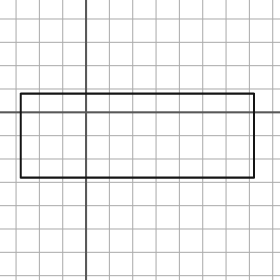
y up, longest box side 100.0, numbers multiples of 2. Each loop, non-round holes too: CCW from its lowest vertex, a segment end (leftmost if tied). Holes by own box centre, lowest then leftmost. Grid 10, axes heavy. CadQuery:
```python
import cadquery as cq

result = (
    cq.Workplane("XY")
    .moveTo(-28.0, -28.0)
    .lineTo(72.0, -28.0)
    .lineTo(72.0, 8.0)
    .lineTo(-28.0, 8.0)
    .close()
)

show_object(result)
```